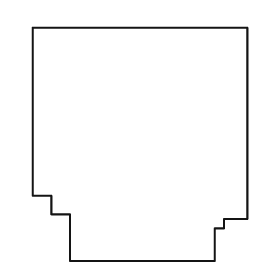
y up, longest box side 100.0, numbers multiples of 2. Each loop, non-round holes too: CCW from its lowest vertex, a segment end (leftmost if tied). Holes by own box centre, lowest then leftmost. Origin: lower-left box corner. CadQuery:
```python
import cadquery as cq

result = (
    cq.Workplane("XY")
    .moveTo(16.0, 0.0)
    .lineTo(78.0, 0.0)
    .lineTo(78.0, 14.0)
    .lineTo(82.0, 14.0)
    .lineTo(82.0, 18.0)
    .lineTo(92.0, 18.0)
    .lineTo(92.0, 100.0)
    .lineTo(0.0, 100.0)
    .lineTo(0.0, 28.0)
    .lineTo(8.0, 28.0)
    .lineTo(8.0, 20.0)
    .lineTo(16.0, 20.0)
    .close()
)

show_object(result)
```